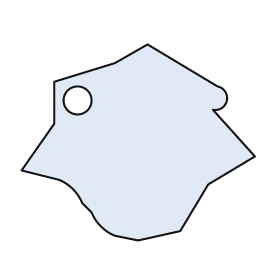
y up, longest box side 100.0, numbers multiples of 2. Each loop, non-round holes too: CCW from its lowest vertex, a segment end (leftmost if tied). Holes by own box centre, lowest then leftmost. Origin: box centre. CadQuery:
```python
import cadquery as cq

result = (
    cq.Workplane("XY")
    .moveTo(0.0, -42.0)
    .lineTo(18.0, -38.0)
    .lineTo(30.0, -18.0)
    .lineTo(50.0, -6.0)
    .lineTo(32.0, 14.0)
    .threePointArc((38.0, 18.0), (34.0, 24.0))
    .lineTo(4.0, 42.0)
    .lineTo(-10.0, 34.0)
    .lineTo(-36.0, 26.0)
    .lineTo(-36.0, 8.0)
    .lineTo(-50.0, -12.0)
    .lineTo(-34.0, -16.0)
    .threePointArc((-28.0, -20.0), (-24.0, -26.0))
    .lineTo(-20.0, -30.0)
    .threePointArc((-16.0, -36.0), (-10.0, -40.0))
    .close()
    .moveTo(-26.0, 18.0)
    .circle(6.0)
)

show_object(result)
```